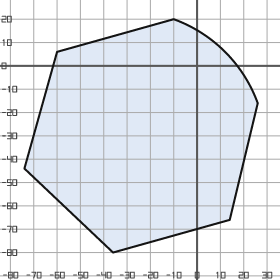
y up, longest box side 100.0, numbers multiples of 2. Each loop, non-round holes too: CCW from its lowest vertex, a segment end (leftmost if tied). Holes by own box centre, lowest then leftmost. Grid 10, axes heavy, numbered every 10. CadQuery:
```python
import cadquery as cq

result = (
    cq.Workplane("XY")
    .moveTo(-36.0, -80.0)
    .lineTo(14.0, -66.0)
    .lineTo(26.0, -16.0)
    .threePointArc((12.0, 6.0), (-10.0, 20.0))
    .lineTo(-60.0, 6.0)
    .lineTo(-74.0, -44.0)
    .close()
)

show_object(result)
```